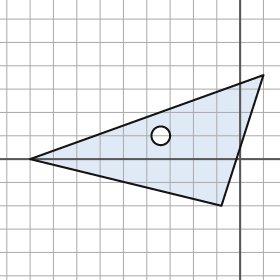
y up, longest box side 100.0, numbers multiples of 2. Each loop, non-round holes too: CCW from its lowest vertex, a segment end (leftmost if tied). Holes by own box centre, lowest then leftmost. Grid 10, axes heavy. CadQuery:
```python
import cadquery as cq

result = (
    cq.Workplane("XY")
    .moveTo(-8.0, -20.0)
    .lineTo(10.0, 36.0)
    .lineTo(-90.0, 0.0)
    .close()
    .moveTo(-34.0, 10.0)
    .circle(4.0)
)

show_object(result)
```